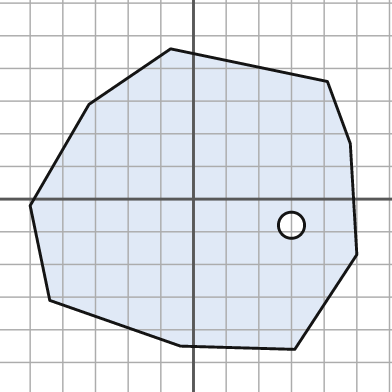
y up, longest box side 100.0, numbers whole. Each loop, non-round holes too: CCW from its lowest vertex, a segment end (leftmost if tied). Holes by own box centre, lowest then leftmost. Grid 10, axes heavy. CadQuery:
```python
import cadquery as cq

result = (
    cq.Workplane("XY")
    .moveTo(31.0, -46.0)
    .lineTo(50.0, -17.0)
    .lineTo(48.0, 17.0)
    .lineTo(41.0, 36.0)
    .lineTo(-7.0, 46.0)
    .lineTo(-32.0, 29.0)
    .lineTo(-50.0, -2.0)
    .lineTo(-44.0, -31.0)
    .lineTo(-4.0, -45.0)
    .close()
    .moveTo(30.0, -8.0)
    .circle(4.0)
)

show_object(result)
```